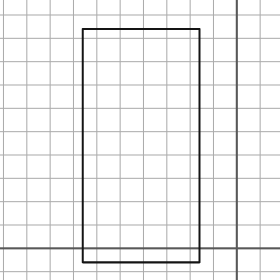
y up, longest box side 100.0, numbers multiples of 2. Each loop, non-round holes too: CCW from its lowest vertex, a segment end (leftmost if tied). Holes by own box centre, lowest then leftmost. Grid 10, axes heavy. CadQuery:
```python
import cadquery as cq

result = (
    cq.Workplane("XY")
    .moveTo(-66.0, -6.0)
    .lineTo(-16.0, -6.0)
    .lineTo(-16.0, 94.0)
    .lineTo(-66.0, 94.0)
    .close()
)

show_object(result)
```